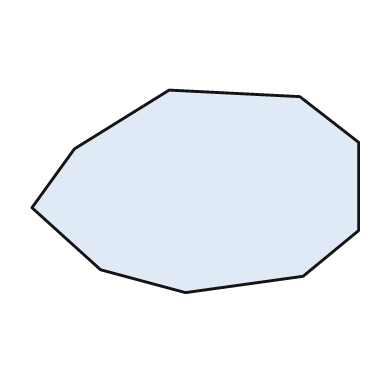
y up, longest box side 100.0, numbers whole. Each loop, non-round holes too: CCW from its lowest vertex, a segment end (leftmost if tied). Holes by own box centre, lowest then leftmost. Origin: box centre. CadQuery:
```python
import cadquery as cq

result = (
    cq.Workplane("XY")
    .moveTo(-3.0, -31.0)
    .lineTo(33.0, -26.0)
    .lineTo(50.0, -12.0)
    .lineTo(50.0, 15.0)
    .lineTo(32.0, 29.0)
    .lineTo(-8.0, 31.0)
    .lineTo(-37.0, 13.0)
    .lineTo(-50.0, -5.0)
    .lineTo(-29.0, -24.0)
    .close()
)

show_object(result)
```